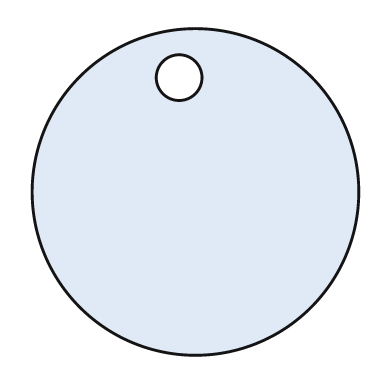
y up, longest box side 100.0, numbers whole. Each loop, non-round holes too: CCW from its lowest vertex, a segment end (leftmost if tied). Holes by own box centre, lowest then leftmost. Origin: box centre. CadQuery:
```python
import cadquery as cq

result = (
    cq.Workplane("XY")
    .moveTo(0.0, 0.0)
    .circle(50.0)
    .moveTo(-5.0, 35.0)
    .circle(7.0)
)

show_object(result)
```